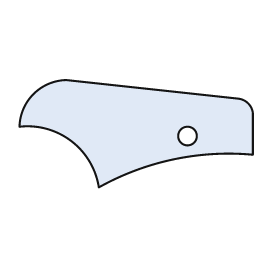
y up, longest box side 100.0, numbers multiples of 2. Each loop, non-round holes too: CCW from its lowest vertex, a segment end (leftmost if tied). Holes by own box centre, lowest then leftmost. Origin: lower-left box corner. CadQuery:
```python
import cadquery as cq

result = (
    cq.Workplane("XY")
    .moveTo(34.0, 0.0)
    .threePointArc((66.0, 12.0), (100.0, 14.0))
    .lineTo(100.0, 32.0)
    .threePointArc((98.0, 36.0), (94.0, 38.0))
    .lineTo(20.0, 46.0)
    .threePointArc((6.0, 40.0), (0.0, 26.0))
    .threePointArc((22.0, 20.0), (34.0, 0.0))
    .close()
    .moveTo(72.0, 22.0)
    .circle(4.0)
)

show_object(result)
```